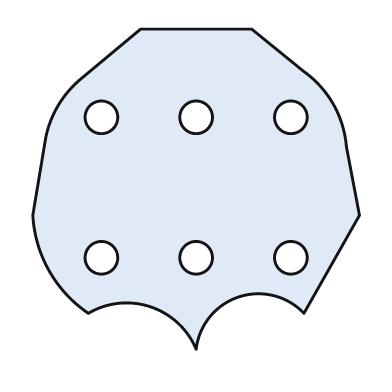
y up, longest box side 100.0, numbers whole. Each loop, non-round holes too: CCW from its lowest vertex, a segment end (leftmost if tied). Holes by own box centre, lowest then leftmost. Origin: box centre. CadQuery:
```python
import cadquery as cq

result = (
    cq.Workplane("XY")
    .moveTo(0.0, -49.0)
    .threePointArc((13.0, -33.0), (33.0, -38.0))
    .lineTo(50.0, -8.0)
    .lineTo(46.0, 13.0)
    .threePointArc((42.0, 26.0), (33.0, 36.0))
    .lineTo(17.0, 49.0)
    .lineTo(-17.0, 49.0)
    .lineTo(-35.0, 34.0)
    .threePointArc((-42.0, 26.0), (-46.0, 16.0))
    .lineTo(-50.0, -8.0)
    .threePointArc((-45.0, -25.0), (-33.0, -38.0))
    .threePointArc((-14.0, -36.0), (0.0, -49.0))
    .close()
    .moveTo(-29.0, -21.0)
    .circle(5.0)
    .moveTo(0.0, -21.0)
    .circle(5.0)
    .moveTo(29.0, -21.0)
    .circle(5.0)
    .moveTo(-29.0, 22.0)
    .circle(5.0)
    .moveTo(0.0, 22.0)
    .circle(5.0)
    .moveTo(29.0, 22.0)
    .circle(5.0)
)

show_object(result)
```